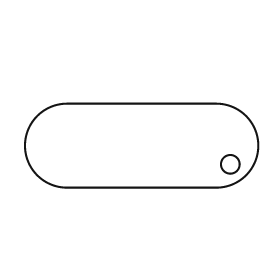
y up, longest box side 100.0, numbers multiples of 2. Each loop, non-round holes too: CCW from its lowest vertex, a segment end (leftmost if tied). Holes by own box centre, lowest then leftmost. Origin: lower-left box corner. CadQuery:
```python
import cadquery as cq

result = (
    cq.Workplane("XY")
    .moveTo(18.0, 0.0)
    .lineTo(82.0, 0.0)
    .threePointArc((100.0, 18.0), (82.0, 36.0))
    .lineTo(18.0, 36.0)
    .threePointArc((0.0, 18.0), (18.0, 0.0))
    .close()
    .moveTo(88.0, 10.0)
    .circle(4.0)
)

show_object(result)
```